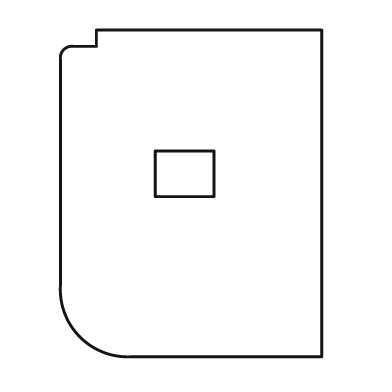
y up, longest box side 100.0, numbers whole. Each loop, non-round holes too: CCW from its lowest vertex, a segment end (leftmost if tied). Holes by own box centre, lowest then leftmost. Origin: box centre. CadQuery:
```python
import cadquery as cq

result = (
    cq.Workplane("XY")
    .moveTo(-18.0, -50.0)
    .lineTo(40.0, -50.0)
    .lineTo(40.0, 50.0)
    .lineTo(-29.0, 50.0)
    .lineTo(-29.0, 45.0)
    .lineTo(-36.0, 45.0)
    .threePointArc((-39.0, 44.0), (-40.0, 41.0))
    .lineTo(-40.0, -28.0)
    .threePointArc((-34.0, -44.0), (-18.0, -50.0))
    .close()
    .moveTo(-11.0, -1.0)
    .lineTo(7.0, -1.0)
    .lineTo(7.0, 13.0)
    .lineTo(-11.0, 13.0)
    .close()
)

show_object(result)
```